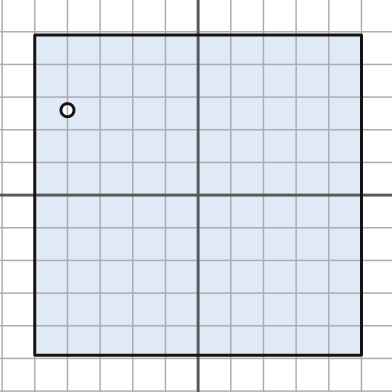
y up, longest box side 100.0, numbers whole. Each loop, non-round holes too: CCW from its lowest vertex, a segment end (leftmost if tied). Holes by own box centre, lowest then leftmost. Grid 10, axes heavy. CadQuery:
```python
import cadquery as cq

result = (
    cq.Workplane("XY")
    .moveTo(-50.0, -49.0)
    .lineTo(50.0, -49.0)
    .lineTo(50.0, 49.0)
    .lineTo(-50.0, 49.0)
    .close()
    .moveTo(-40.0, 26.0)
    .circle(2.0)
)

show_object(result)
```